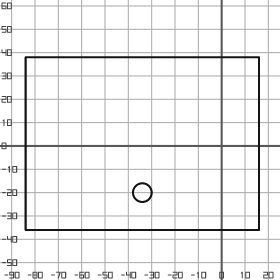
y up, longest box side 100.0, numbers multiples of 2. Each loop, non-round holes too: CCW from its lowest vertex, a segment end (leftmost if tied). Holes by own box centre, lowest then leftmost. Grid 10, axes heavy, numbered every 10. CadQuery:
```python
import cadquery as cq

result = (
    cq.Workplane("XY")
    .moveTo(-84.0, -36.0)
    .lineTo(16.0, -36.0)
    .lineTo(16.0, 38.0)
    .lineTo(-84.0, 38.0)
    .close()
    .moveTo(-34.0, -20.0)
    .circle(4.0)
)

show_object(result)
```